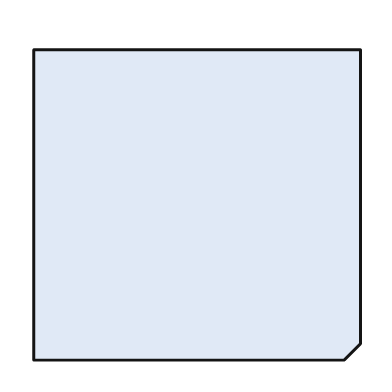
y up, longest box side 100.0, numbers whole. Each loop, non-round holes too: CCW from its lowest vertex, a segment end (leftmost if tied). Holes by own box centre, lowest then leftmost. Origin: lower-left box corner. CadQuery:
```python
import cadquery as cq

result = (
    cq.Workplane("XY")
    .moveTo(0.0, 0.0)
    .lineTo(95.0, 0.0)
    .lineTo(100.0, 5.0)
    .lineTo(100.0, 95.0)
    .lineTo(0.0, 95.0)
    .close()
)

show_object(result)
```